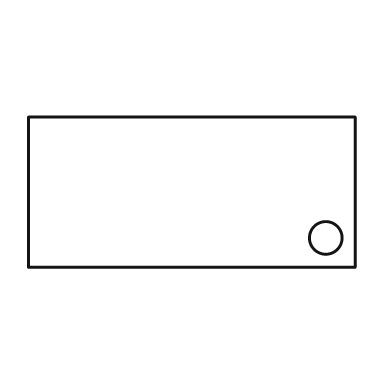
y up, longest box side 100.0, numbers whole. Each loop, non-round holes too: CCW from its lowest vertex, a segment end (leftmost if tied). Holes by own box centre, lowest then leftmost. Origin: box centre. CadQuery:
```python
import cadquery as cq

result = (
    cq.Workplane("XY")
    .moveTo(-50.0, -23.0)
    .lineTo(50.0, -23.0)
    .lineTo(50.0, 23.0)
    .lineTo(-50.0, 23.0)
    .close()
    .moveTo(41.0, -14.0)
    .circle(5.0)
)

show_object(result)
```